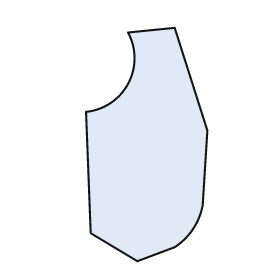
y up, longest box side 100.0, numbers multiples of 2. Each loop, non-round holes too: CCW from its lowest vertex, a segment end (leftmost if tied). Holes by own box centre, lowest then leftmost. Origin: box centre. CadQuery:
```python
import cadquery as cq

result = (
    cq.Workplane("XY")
    .moveTo(-4.0, -50.0)
    .lineTo(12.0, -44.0)
    .threePointArc((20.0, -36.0), (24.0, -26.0))
    .lineTo(26.0, 6.0)
    .lineTo(12.0, 50.0)
    .lineTo(-8.0, 48.0)
    .threePointArc((-8.0, 26.0), (-26.0, 14.0))
    .lineTo(-24.0, -38.0)
    .close()
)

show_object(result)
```